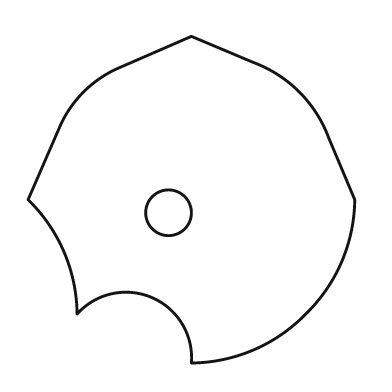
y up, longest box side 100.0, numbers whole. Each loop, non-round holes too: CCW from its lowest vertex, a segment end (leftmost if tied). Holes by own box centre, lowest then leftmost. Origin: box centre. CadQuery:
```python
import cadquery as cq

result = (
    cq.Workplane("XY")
    .moveTo(0.0, -50.0)
    .threePointArc((19.0, -46.0), (35.0, -35.0))
    .threePointArc((46.0, -19.0), (50.0, 0.0))
    .lineTo(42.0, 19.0)
    .threePointArc((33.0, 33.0), (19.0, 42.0))
    .lineTo(0.0, 50.0)
    .lineTo(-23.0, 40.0)
    .threePointArc((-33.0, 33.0), (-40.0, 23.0))
    .lineTo(-50.0, 0.0)
    .threePointArc((-39.0, -16.0), (-35.0, -35.0))
    .threePointArc((-12.0, -30.0), (0.0, -50.0))
    .close()
    .moveTo(-7.0, -4.0)
    .circle(7.0)
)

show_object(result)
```